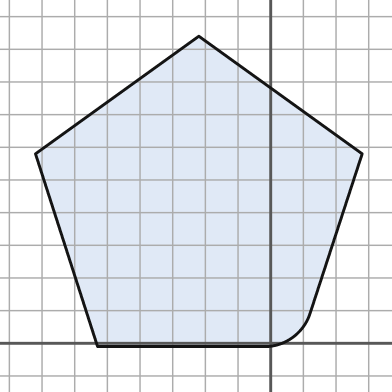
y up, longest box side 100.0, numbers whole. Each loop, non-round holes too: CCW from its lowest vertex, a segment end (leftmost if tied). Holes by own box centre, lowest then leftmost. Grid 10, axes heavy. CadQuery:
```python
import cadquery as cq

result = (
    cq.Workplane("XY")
    .moveTo(-53.0, -1.0)
    .lineTo(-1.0, -1.0)
    .threePointArc((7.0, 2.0), (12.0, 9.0))
    .lineTo(28.0, 58.0)
    .lineTo(-22.0, 94.0)
    .lineTo(-72.0, 58.0)
    .close()
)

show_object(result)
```